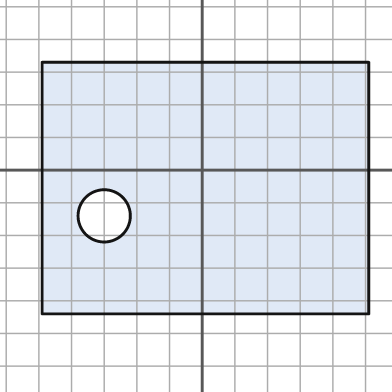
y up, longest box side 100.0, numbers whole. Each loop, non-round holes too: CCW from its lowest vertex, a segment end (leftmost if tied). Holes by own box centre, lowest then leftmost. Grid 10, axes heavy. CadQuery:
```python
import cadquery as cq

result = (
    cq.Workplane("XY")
    .moveTo(-49.0, -44.0)
    .lineTo(51.0, -44.0)
    .lineTo(51.0, 33.0)
    .lineTo(-49.0, 33.0)
    .close()
    .moveTo(-30.0, -14.0)
    .circle(8.0)
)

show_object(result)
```